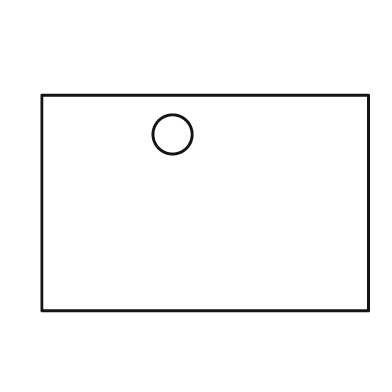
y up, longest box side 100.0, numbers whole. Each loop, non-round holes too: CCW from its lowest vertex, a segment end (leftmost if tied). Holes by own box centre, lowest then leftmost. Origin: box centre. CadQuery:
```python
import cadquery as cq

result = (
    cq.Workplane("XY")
    .moveTo(-50.0, -33.0)
    .lineTo(50.0, -33.0)
    .lineTo(50.0, 33.0)
    .lineTo(-50.0, 33.0)
    .close()
    .moveTo(-10.0, 21.0)
    .circle(6.0)
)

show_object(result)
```